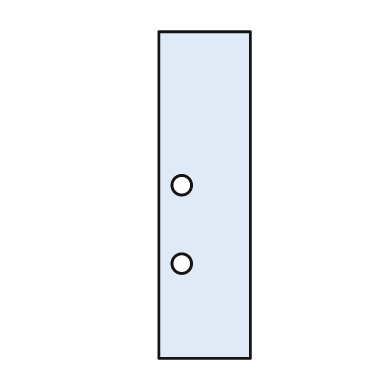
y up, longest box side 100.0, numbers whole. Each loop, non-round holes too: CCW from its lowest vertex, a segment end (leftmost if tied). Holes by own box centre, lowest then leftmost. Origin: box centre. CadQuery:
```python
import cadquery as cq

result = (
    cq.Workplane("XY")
    .moveTo(-14.0, -50.0)
    .lineTo(14.0, -50.0)
    .lineTo(14.0, 50.0)
    .lineTo(-14.0, 50.0)
    .close()
    .moveTo(-7.0, -21.0)
    .circle(3.0)
    .moveTo(-7.0, 3.0)
    .circle(3.0)
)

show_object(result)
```